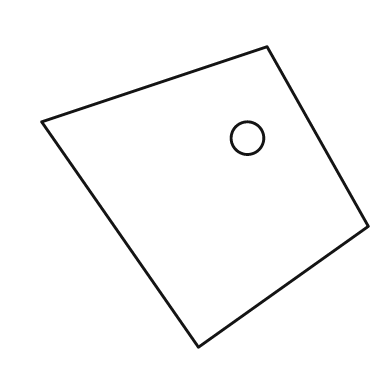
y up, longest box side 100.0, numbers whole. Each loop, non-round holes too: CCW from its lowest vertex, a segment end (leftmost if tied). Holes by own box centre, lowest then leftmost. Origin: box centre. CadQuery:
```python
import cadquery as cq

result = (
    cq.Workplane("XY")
    .moveTo(-2.0, -46.0)
    .lineTo(50.0, -9.0)
    .lineTo(19.0, 46.0)
    .lineTo(-50.0, 23.0)
    .close()
    .moveTo(13.0, 18.0)
    .circle(5.0)
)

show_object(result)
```